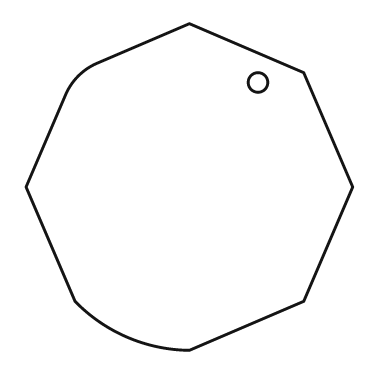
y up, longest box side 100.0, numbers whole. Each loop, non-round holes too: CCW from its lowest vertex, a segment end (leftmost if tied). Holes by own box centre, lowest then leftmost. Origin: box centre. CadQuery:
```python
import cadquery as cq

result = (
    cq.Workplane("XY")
    .moveTo(0.0, -50.0)
    .lineTo(35.0, -35.0)
    .lineTo(50.0, 0.0)
    .lineTo(35.0, 35.0)
    .lineTo(0.0, 50.0)
    .lineTo(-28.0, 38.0)
    .threePointArc((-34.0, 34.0), (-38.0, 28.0))
    .lineTo(-50.0, 0.0)
    .lineTo(-35.0, -35.0)
    .threePointArc((-19.0, -46.0), (0.0, -50.0))
    .close()
    .moveTo(21.0, 32.0)
    .circle(3.0)
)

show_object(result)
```